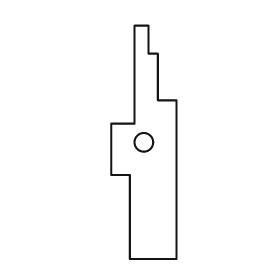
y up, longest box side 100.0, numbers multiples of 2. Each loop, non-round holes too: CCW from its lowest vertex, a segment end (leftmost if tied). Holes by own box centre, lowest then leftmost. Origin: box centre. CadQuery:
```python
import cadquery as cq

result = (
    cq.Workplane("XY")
    .moveTo(-6.0, -50.0)
    .lineTo(14.0, -50.0)
    .lineTo(14.0, 18.0)
    .lineTo(6.0, 18.0)
    .lineTo(6.0, 38.0)
    .lineTo(2.0, 38.0)
    .lineTo(2.0, 50.0)
    .lineTo(-4.0, 50.0)
    .lineTo(-4.0, 8.0)
    .lineTo(-14.0, 8.0)
    .lineTo(-14.0, -14.0)
    .lineTo(-6.0, -14.0)
    .close()
    .moveTo(0.0, 0.0)
    .circle(4.0)
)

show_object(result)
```